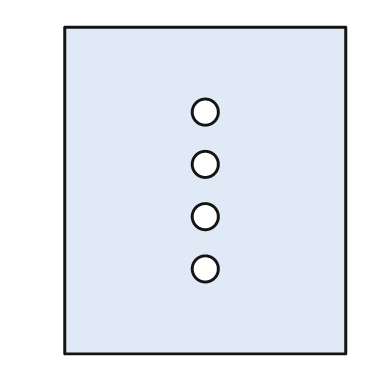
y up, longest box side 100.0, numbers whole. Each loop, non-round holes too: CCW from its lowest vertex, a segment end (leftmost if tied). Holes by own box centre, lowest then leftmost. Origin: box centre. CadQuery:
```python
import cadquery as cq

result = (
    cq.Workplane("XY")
    .moveTo(-43.0, -50.0)
    .lineTo(43.0, -50.0)
    .lineTo(43.0, 50.0)
    .lineTo(-43.0, 50.0)
    .close()
    .moveTo(0.0, -24.0)
    .circle(4.0)
    .moveTo(0.0, -8.0)
    .circle(4.0)
    .moveTo(0.0, 8.0)
    .circle(4.0)
    .moveTo(0.0, 24.0)
    .circle(4.0)
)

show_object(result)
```